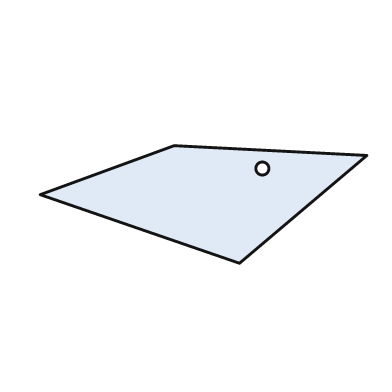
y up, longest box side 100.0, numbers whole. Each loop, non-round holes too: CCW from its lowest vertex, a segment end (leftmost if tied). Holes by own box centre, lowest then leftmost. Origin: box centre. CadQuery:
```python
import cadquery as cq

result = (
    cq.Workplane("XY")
    .moveTo(11.0, -18.0)
    .lineTo(50.0, 15.0)
    .lineTo(-9.0, 18.0)
    .lineTo(-50.0, 3.0)
    .close()
    .moveTo(18.0, 11.0)
    .circle(2.0)
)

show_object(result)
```